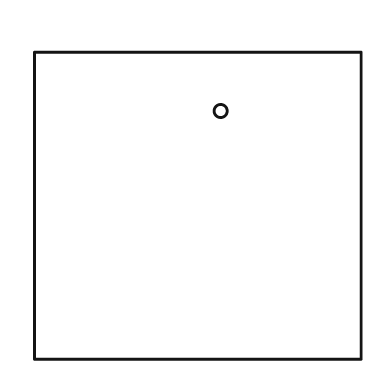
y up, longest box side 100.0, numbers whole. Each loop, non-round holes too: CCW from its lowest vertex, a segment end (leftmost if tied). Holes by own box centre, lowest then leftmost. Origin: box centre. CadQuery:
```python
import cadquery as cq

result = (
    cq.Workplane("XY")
    .moveTo(-50.0, -47.0)
    .lineTo(50.0, -47.0)
    .lineTo(50.0, 47.0)
    .lineTo(-50.0, 47.0)
    .close()
    .moveTo(7.0, 29.0)
    .circle(2.0)
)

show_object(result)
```